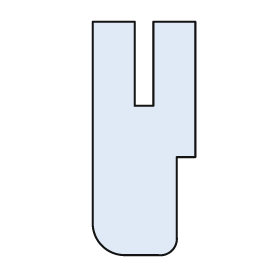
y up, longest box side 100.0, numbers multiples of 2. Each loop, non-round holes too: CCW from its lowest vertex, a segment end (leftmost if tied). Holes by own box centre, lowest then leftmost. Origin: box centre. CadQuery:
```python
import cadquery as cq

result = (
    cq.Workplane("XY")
    .moveTo(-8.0, -50.0)
    .lineTo(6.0, -50.0)
    .threePointArc((12.0, -48.0), (14.0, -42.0))
    .lineTo(14.0, -8.0)
    .lineTo(22.0, -8.0)
    .lineTo(22.0, 50.0)
    .lineTo(4.0, 50.0)
    .lineTo(4.0, 14.0)
    .lineTo(-4.0, 14.0)
    .lineTo(-4.0, 50.0)
    .lineTo(-22.0, 50.0)
    .lineTo(-22.0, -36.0)
    .threePointArc((-18.0, -46.0), (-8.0, -50.0))
    .close()
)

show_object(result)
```